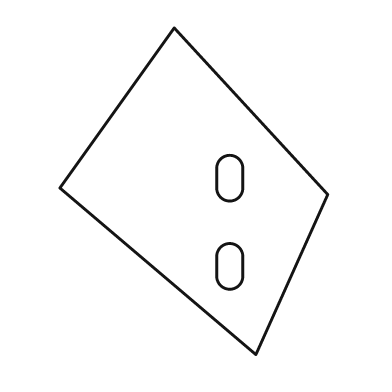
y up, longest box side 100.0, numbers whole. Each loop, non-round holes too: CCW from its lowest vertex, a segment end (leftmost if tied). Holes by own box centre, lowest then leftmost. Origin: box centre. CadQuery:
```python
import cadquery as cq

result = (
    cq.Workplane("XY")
    .moveTo(19.0, -50.0)
    .lineTo(41.0, -1.0)
    .lineTo(-6.0, 50.0)
    .lineTo(-41.0, 1.0)
    .close()
    .moveTo(7.0, -26.0)
    .threePointArc((11.0, -30.0), (15.0, -26.0))
    .lineTo(15.0, -20.0)
    .threePointArc((11.0, -16.0), (7.0, -20.0))
    .close()
    .moveTo(7.0, 1.0)
    .threePointArc((11.0, -3.0), (15.0, 1.0))
    .lineTo(15.0, 7.0)
    .threePointArc((11.0, 11.0), (7.0, 7.0))
    .close()
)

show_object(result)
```